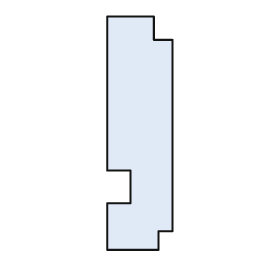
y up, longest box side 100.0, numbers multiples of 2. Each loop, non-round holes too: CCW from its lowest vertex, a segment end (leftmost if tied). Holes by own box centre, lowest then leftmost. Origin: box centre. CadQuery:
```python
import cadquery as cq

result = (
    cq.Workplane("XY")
    .moveTo(-14.0, -50.0)
    .lineTo(8.0, -50.0)
    .lineTo(8.0, -42.0)
    .lineTo(14.0, -42.0)
    .lineTo(14.0, 40.0)
    .lineTo(6.0, 40.0)
    .lineTo(6.0, 50.0)
    .lineTo(-14.0, 50.0)
    .lineTo(-14.0, -16.0)
    .lineTo(-4.0, -16.0)
    .lineTo(-4.0, -30.0)
    .lineTo(-14.0, -30.0)
    .close()
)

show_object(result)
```